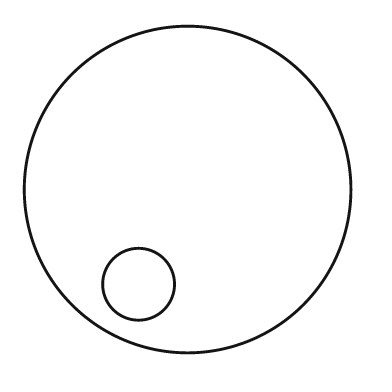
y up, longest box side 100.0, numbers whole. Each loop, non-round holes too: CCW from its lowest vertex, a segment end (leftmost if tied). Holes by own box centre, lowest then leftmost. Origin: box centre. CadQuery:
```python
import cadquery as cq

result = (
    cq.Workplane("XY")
    .moveTo(0.0, 0.0)
    .circle(50.0)
    .moveTo(-15.0, -29.0)
    .circle(11.0)
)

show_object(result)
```